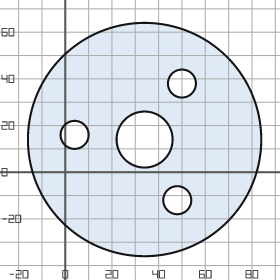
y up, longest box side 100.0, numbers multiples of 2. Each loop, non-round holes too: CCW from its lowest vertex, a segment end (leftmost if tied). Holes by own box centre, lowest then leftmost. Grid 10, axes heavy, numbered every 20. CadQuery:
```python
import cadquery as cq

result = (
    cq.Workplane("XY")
    .moveTo(34.0, 14.0)
    .circle(50.0)
    .moveTo(48.0, -12.0)
    .circle(6.0)
    .moveTo(34.0, 14.0)
    .circle(12.0)
    .moveTo(4.0, 16.0)
    .circle(6.0)
    .moveTo(50.0, 38.0)
    .circle(6.0)
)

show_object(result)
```